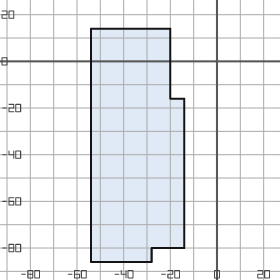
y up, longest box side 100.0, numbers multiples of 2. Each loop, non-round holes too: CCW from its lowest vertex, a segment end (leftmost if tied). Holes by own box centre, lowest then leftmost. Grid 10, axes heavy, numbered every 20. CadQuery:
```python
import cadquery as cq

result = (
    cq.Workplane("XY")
    .moveTo(-54.0, -86.0)
    .lineTo(-28.0, -86.0)
    .lineTo(-28.0, -80.0)
    .lineTo(-14.0, -80.0)
    .lineTo(-14.0, -16.0)
    .lineTo(-20.0, -16.0)
    .lineTo(-20.0, 14.0)
    .lineTo(-54.0, 14.0)
    .close()
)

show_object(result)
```